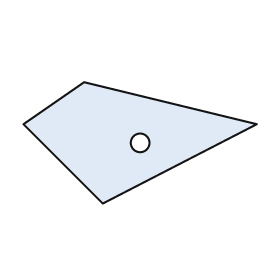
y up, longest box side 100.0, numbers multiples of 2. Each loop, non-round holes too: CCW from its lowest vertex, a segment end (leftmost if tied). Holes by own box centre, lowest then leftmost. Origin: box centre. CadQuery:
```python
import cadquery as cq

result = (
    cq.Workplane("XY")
    .moveTo(-16.0, -26.0)
    .lineTo(50.0, 8.0)
    .lineTo(-24.0, 26.0)
    .lineTo(-50.0, 8.0)
    .close()
    .moveTo(0.0, 0.0)
    .circle(4.0)
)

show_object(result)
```